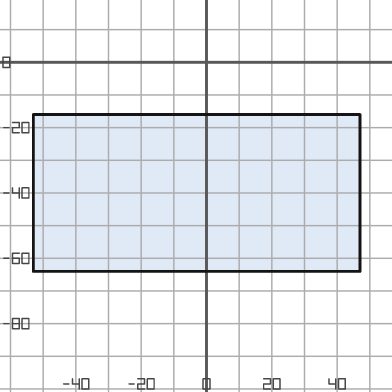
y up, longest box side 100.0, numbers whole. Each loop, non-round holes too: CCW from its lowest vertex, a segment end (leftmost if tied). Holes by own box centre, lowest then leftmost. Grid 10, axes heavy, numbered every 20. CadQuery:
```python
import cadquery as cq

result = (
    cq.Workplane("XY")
    .moveTo(-53.0, -64.0)
    .lineTo(47.0, -64.0)
    .lineTo(47.0, -16.0)
    .lineTo(-53.0, -16.0)
    .close()
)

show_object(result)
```